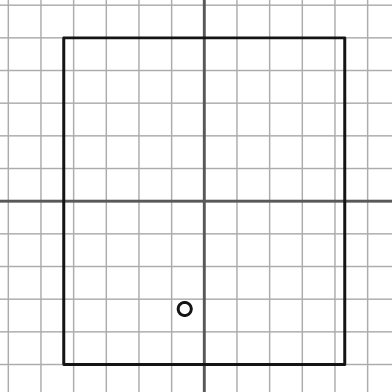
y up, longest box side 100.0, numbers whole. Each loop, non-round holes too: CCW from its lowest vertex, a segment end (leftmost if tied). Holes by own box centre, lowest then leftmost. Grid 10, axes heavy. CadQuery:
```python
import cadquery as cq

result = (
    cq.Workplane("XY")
    .moveTo(-43.0, -50.0)
    .lineTo(43.0, -50.0)
    .lineTo(43.0, 50.0)
    .lineTo(-43.0, 50.0)
    .close()
    .moveTo(-6.0, -33.0)
    .circle(2.0)
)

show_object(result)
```